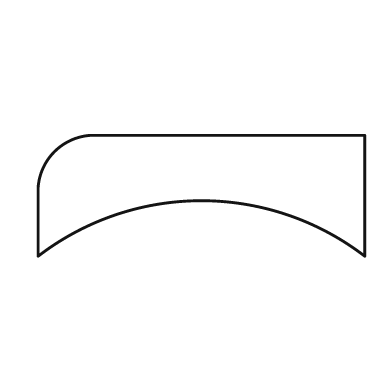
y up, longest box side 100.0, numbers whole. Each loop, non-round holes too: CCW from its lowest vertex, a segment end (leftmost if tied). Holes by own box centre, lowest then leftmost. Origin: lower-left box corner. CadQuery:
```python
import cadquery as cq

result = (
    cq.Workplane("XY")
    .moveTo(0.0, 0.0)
    .threePointArc((50.0, 17.0), (100.0, 0.0))
    .lineTo(100.0, 37.0)
    .lineTo(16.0, 37.0)
    .threePointArc((5.0, 32.0), (0.0, 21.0))
    .close()
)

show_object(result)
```